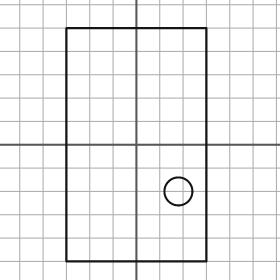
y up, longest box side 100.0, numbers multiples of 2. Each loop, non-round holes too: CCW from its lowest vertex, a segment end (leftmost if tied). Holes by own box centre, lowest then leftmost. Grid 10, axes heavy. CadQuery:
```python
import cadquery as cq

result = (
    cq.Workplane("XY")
    .moveTo(-30.0, -50.0)
    .lineTo(30.0, -50.0)
    .lineTo(30.0, 50.0)
    .lineTo(-30.0, 50.0)
    .close()
    .moveTo(18.0, -20.0)
    .circle(6.0)
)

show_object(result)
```